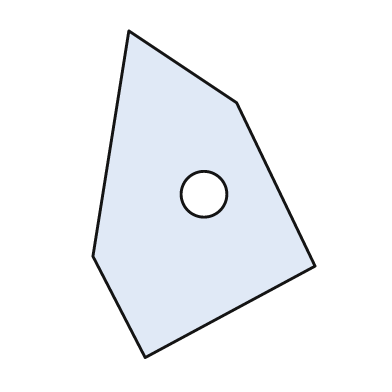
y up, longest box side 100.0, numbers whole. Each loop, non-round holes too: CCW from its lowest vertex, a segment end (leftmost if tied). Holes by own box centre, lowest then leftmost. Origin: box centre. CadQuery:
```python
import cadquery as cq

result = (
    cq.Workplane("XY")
    .moveTo(-18.0, -50.0)
    .lineTo(34.0, -22.0)
    .lineTo(10.0, 28.0)
    .lineTo(-23.0, 50.0)
    .lineTo(-34.0, -19.0)
    .close()
    .moveTo(0.0, 0.0)
    .circle(7.0)
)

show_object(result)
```